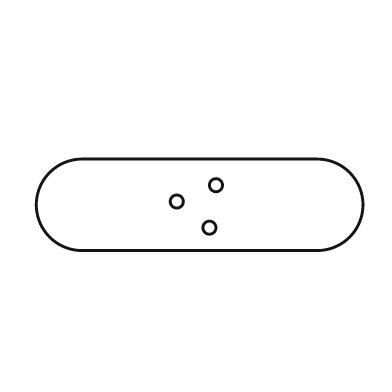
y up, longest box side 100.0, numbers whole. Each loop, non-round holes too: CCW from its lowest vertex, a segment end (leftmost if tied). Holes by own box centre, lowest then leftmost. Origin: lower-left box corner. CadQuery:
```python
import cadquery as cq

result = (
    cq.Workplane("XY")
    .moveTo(14.0, 0.0)
    .lineTo(86.0, 0.0)
    .threePointArc((100.0, 14.0), (86.0, 28.0))
    .lineTo(14.0, 28.0)
    .threePointArc((0.0, 14.0), (14.0, 0.0))
    .close()
    .moveTo(53.0, 7.0)
    .circle(2.0)
    .moveTo(43.0, 15.0)
    .circle(2.0)
    .moveTo(55.0, 20.0)
    .circle(2.0)
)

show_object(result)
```